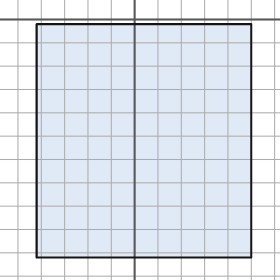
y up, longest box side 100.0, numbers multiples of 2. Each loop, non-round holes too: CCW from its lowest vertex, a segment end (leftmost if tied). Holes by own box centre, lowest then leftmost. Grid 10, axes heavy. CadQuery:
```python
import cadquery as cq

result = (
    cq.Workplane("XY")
    .moveTo(-42.0, -102.0)
    .lineTo(50.0, -102.0)
    .lineTo(50.0, -2.0)
    .lineTo(-42.0, -2.0)
    .close()
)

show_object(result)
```